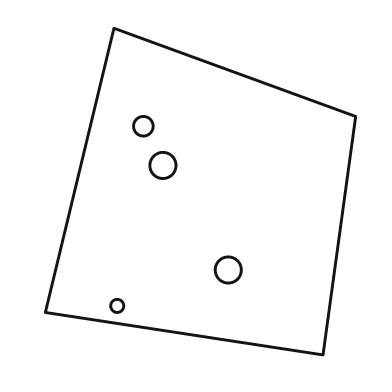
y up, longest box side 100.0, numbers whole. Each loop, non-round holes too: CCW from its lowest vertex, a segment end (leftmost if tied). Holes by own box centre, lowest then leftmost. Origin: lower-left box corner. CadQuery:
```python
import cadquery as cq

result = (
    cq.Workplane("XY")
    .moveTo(85.0, 0.0)
    .lineTo(95.0, 73.0)
    .lineTo(21.0, 100.0)
    .lineTo(0.0, 13.0)
    .close()
    .moveTo(22.0, 15.0)
    .circle(2.0)
    .moveTo(56.0, 26.0)
    .circle(4.0)
    .moveTo(36.0, 58.0)
    .circle(4.0)
    .moveTo(30.0, 70.0)
    .circle(3.0)
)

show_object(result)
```